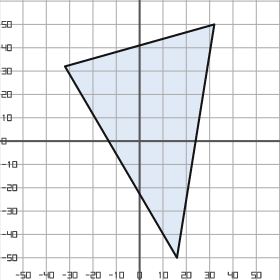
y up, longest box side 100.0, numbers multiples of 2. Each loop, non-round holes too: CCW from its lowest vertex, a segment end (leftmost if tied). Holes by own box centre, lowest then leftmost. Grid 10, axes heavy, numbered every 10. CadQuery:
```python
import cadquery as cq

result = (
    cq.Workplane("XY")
    .moveTo(16.0, -50.0)
    .lineTo(32.0, 50.0)
    .lineTo(-32.0, 32.0)
    .close()
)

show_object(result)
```